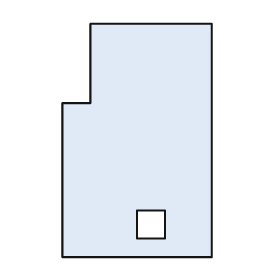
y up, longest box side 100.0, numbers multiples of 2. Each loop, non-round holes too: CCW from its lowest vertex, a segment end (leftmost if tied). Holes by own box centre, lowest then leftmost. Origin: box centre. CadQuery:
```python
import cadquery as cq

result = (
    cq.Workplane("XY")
    .moveTo(-32.0, -50.0)
    .lineTo(32.0, -50.0)
    .lineTo(32.0, 50.0)
    .lineTo(-20.0, 50.0)
    .lineTo(-20.0, 16.0)
    .lineTo(-32.0, 16.0)
    .close()
    .moveTo(0.0, -42.0)
    .lineTo(12.0, -42.0)
    .lineTo(12.0, -30.0)
    .lineTo(0.0, -30.0)
    .close()
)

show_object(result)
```